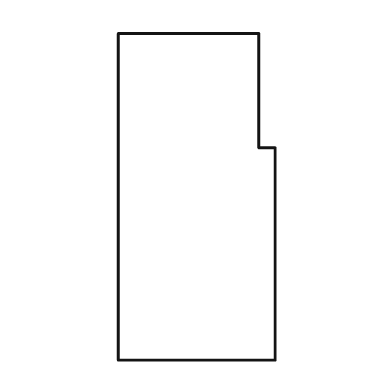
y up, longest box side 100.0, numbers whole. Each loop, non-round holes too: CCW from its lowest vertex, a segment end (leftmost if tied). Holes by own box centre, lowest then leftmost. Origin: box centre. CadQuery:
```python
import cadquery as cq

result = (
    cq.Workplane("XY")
    .moveTo(-24.0, -50.0)
    .lineTo(24.0, -50.0)
    .lineTo(24.0, 15.0)
    .lineTo(19.0, 15.0)
    .lineTo(19.0, 50.0)
    .lineTo(-24.0, 50.0)
    .close()
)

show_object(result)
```